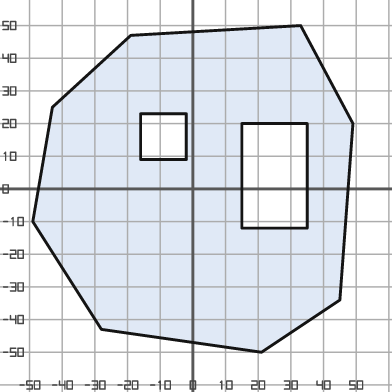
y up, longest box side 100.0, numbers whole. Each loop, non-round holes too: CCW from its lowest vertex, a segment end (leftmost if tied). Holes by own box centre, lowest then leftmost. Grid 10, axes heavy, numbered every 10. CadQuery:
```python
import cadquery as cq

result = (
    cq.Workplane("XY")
    .moveTo(21.0, -50.0)
    .lineTo(45.0, -34.0)
    .lineTo(49.0, 20.0)
    .lineTo(33.0, 50.0)
    .lineTo(-19.0, 47.0)
    .lineTo(-43.0, 25.0)
    .lineTo(-49.0, -10.0)
    .lineTo(-28.0, -43.0)
    .close()
    .moveTo(15.0, -12.0)
    .lineTo(35.0, -12.0)
    .lineTo(35.0, 20.0)
    .lineTo(15.0, 20.0)
    .close()
    .moveTo(-16.0, 9.0)
    .lineTo(-2.0, 9.0)
    .lineTo(-2.0, 23.0)
    .lineTo(-16.0, 23.0)
    .close()
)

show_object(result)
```